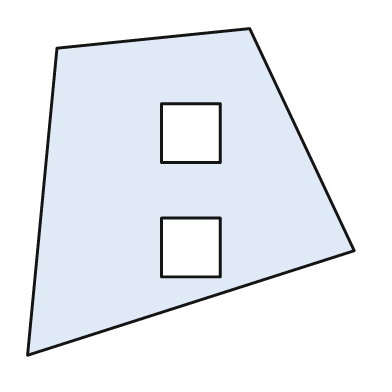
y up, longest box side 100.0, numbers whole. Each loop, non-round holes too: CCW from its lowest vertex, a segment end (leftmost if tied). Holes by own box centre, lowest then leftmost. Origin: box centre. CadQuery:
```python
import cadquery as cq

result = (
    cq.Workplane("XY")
    .moveTo(-50.0, -50.0)
    .lineTo(50.0, -18.0)
    .lineTo(18.0, 50.0)
    .lineTo(-41.0, 44.0)
    .close()
    .moveTo(-9.0, -26.0)
    .lineTo(9.0, -26.0)
    .lineTo(9.0, -8.0)
    .lineTo(-9.0, -8.0)
    .close()
    .moveTo(-9.0, 9.0)
    .lineTo(9.0, 9.0)
    .lineTo(9.0, 27.0)
    .lineTo(-9.0, 27.0)
    .close()
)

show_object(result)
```